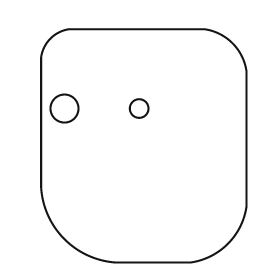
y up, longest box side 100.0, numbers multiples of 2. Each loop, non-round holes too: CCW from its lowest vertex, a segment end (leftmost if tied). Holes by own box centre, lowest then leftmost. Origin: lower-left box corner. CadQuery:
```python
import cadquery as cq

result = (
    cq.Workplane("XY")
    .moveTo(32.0, 0.0)
    .lineTo(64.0, 0.0)
    .threePointArc((80.0, 8.0), (88.0, 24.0))
    .lineTo(88.0, 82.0)
    .threePointArc((82.0, 94.0), (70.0, 100.0))
    .lineTo(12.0, 100.0)
    .threePointArc((4.0, 96.0), (0.0, 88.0))
    .lineTo(0.0, 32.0)
    .threePointArc((10.0, 10.0), (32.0, 0.0))
    .close()
    .moveTo(10.0, 66.0)
    .circle(6.0)
    .moveTo(42.0, 66.0)
    .circle(4.0)
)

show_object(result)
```